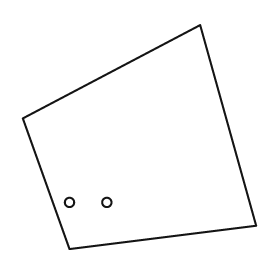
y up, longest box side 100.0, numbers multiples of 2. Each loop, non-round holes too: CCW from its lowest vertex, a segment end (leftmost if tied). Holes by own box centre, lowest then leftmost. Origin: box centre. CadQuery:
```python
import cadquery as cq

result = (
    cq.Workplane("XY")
    .moveTo(-30.0, -48.0)
    .lineTo(50.0, -38.0)
    .lineTo(26.0, 48.0)
    .lineTo(-50.0, 8.0)
    .close()
    .moveTo(-30.0, -28.0)
    .circle(2.0)
    .moveTo(-14.0, -28.0)
    .circle(2.0)
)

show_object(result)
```